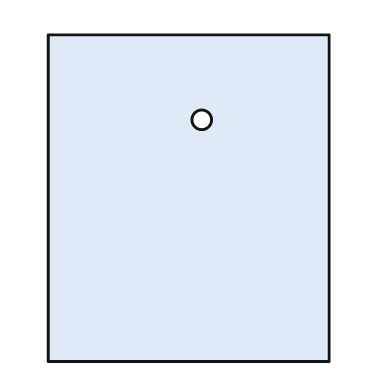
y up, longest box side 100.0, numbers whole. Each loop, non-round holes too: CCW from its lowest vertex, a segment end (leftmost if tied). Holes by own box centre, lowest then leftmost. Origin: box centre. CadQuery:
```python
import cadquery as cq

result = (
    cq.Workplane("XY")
    .moveTo(-43.0, -50.0)
    .lineTo(43.0, -50.0)
    .lineTo(43.0, 50.0)
    .lineTo(-43.0, 50.0)
    .close()
    .moveTo(4.0, 24.0)
    .circle(3.0)
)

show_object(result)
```